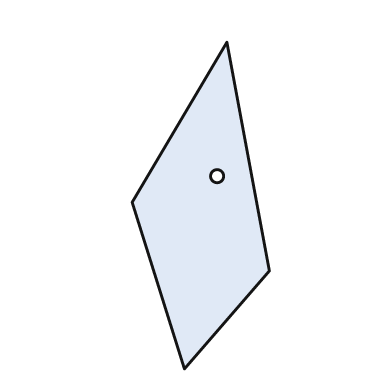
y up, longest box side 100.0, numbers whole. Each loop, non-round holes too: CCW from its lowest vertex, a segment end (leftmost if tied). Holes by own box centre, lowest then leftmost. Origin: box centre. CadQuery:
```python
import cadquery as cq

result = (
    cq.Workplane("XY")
    .moveTo(-5.0, -50.0)
    .lineTo(21.0, -20.0)
    .lineTo(8.0, 50.0)
    .lineTo(-21.0, 1.0)
    .close()
    .moveTo(5.0, 9.0)
    .circle(2.0)
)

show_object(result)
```